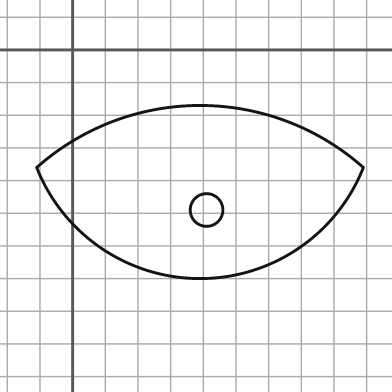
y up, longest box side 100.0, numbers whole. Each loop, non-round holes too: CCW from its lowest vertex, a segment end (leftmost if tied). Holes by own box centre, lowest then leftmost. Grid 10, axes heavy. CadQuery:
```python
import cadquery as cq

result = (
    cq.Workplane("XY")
    .moveTo(-11.0, -36.0)
    .threePointArc((39.0, -70.0), (89.0, -36.0))
    .threePointArc((39.0, -17.0), (-11.0, -36.0))
    .close()
    .moveTo(41.0, -49.0)
    .circle(5.0)
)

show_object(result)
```